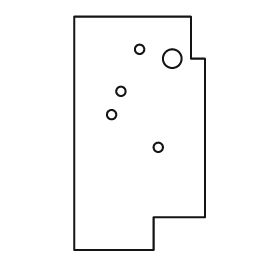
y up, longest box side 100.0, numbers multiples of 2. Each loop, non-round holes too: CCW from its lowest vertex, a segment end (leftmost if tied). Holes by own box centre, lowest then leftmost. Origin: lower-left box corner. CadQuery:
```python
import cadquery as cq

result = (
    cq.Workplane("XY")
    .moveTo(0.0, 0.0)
    .lineTo(34.0, 0.0)
    .lineTo(34.0, 14.0)
    .lineTo(56.0, 14.0)
    .lineTo(56.0, 82.0)
    .lineTo(50.0, 82.0)
    .lineTo(50.0, 100.0)
    .lineTo(0.0, 100.0)
    .close()
    .moveTo(36.0, 44.0)
    .circle(2.0)
    .moveTo(16.0, 58.0)
    .circle(2.0)
    .moveTo(20.0, 68.0)
    .circle(2.0)
    .moveTo(42.0, 82.0)
    .circle(4.0)
    .moveTo(28.0, 86.0)
    .circle(2.0)
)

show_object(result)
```